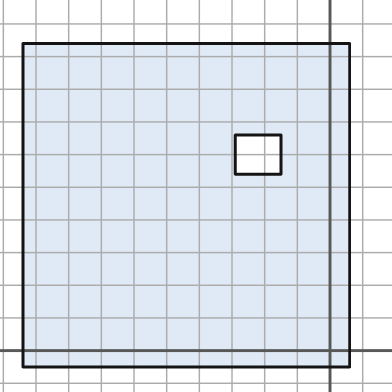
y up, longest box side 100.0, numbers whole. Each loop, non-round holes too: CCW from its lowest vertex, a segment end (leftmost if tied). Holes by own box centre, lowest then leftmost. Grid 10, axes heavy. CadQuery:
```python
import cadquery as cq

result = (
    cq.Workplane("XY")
    .moveTo(-94.0, -5.0)
    .lineTo(6.0, -5.0)
    .lineTo(6.0, 94.0)
    .lineTo(-94.0, 94.0)
    .close()
    .moveTo(-29.0, 54.0)
    .lineTo(-15.0, 54.0)
    .lineTo(-15.0, 66.0)
    .lineTo(-29.0, 66.0)
    .close()
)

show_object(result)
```